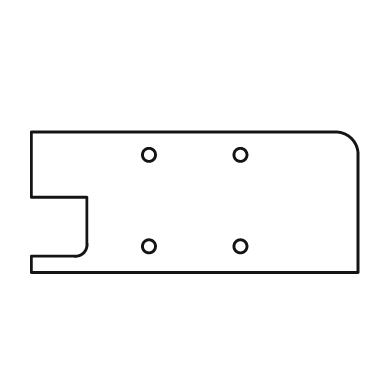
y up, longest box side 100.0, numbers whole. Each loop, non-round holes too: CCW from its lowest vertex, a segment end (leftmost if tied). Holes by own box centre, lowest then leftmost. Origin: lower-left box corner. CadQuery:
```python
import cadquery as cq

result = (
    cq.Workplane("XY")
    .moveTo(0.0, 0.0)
    .lineTo(100.0, 0.0)
    .lineTo(100.0, 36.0)
    .threePointArc((98.0, 41.0), (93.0, 43.0))
    .lineTo(0.0, 43.0)
    .lineTo(0.0, 23.0)
    .lineTo(17.0, 23.0)
    .lineTo(17.0, 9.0)
    .threePointArc((16.0, 6.0), (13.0, 5.0))
    .lineTo(0.0, 5.0)
    .close()
    .moveTo(36.0, 8.0)
    .circle(2.0)
    .moveTo(64.0, 8.0)
    .circle(2.0)
    .moveTo(36.0, 36.0)
    .circle(2.0)
    .moveTo(64.0, 36.0)
    .circle(2.0)
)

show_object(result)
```